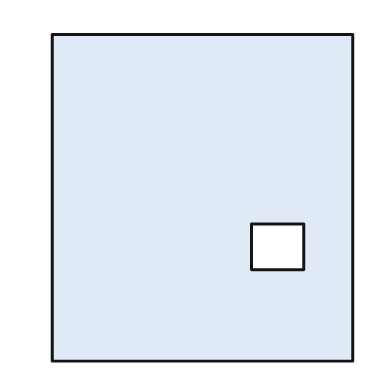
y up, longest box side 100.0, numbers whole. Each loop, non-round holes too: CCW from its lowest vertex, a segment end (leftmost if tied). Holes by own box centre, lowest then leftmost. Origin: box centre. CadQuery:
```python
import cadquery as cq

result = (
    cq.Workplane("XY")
    .moveTo(-46.0, -50.0)
    .lineTo(46.0, -50.0)
    .lineTo(46.0, 50.0)
    .lineTo(-46.0, 50.0)
    .close()
    .moveTo(15.0, -22.0)
    .lineTo(31.0, -22.0)
    .lineTo(31.0, -8.0)
    .lineTo(15.0, -8.0)
    .close()
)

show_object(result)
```